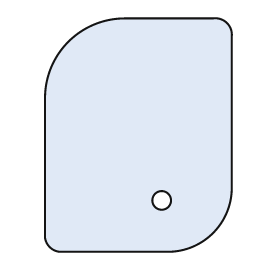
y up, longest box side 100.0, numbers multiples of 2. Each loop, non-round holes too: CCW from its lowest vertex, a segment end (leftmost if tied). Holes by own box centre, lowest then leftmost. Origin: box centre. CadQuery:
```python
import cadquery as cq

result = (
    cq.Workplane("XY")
    .moveTo(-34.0, -50.0)
    .lineTo(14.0, -50.0)
    .threePointArc((32.0, -42.0), (40.0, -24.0))
    .lineTo(40.0, 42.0)
    .threePointArc((38.0, 48.0), (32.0, 50.0))
    .lineTo(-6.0, 50.0)
    .threePointArc((-30.0, 40.0), (-40.0, 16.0))
    .lineTo(-40.0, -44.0)
    .threePointArc((-38.0, -48.0), (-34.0, -50.0))
    .close()
    .moveTo(10.0, -28.0)
    .circle(4.0)
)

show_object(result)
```